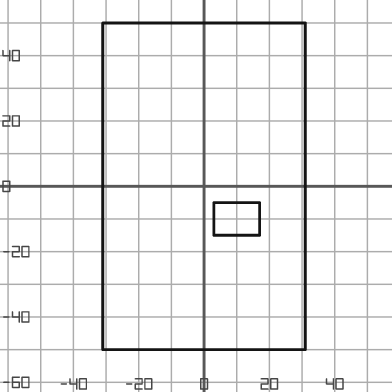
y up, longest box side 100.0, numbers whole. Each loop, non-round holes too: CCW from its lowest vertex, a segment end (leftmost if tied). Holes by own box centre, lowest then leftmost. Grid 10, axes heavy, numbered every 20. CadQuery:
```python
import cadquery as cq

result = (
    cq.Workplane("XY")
    .moveTo(-31.0, -50.0)
    .lineTo(31.0, -50.0)
    .lineTo(31.0, 50.0)
    .lineTo(-31.0, 50.0)
    .close()
    .moveTo(3.0, -15.0)
    .lineTo(17.0, -15.0)
    .lineTo(17.0, -5.0)
    .lineTo(3.0, -5.0)
    .close()
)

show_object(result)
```